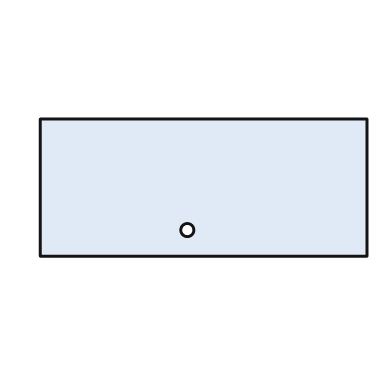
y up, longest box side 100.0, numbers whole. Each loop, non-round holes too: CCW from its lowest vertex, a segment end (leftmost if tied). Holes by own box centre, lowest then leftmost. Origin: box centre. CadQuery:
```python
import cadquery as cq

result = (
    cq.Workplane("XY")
    .moveTo(-50.0, -21.0)
    .lineTo(50.0, -21.0)
    .lineTo(50.0, 21.0)
    .lineTo(-50.0, 21.0)
    .close()
    .moveTo(-5.0, -13.0)
    .circle(2.0)
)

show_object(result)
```